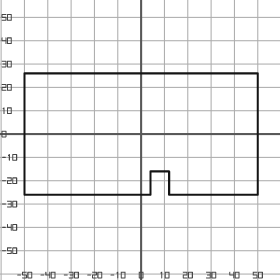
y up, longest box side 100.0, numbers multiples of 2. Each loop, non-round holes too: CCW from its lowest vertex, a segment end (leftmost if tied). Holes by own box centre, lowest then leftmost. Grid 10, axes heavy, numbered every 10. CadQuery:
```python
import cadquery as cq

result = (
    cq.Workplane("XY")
    .moveTo(-50.0, -26.0)
    .lineTo(4.0, -26.0)
    .lineTo(4.0, -16.0)
    .lineTo(12.0, -16.0)
    .lineTo(12.0, -26.0)
    .lineTo(50.0, -26.0)
    .lineTo(50.0, 26.0)
    .lineTo(-50.0, 26.0)
    .close()
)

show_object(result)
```